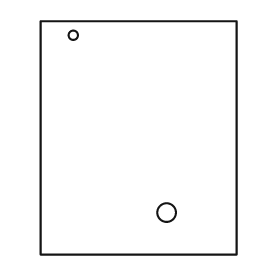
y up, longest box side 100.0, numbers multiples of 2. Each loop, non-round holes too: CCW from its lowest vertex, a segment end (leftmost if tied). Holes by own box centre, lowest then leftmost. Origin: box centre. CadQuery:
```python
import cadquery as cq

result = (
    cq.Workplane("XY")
    .moveTo(-42.0, -50.0)
    .lineTo(42.0, -50.0)
    .lineTo(42.0, 50.0)
    .lineTo(-42.0, 50.0)
    .close()
    .moveTo(12.0, -32.0)
    .circle(4.0)
    .moveTo(-28.0, 44.0)
    .circle(2.0)
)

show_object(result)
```